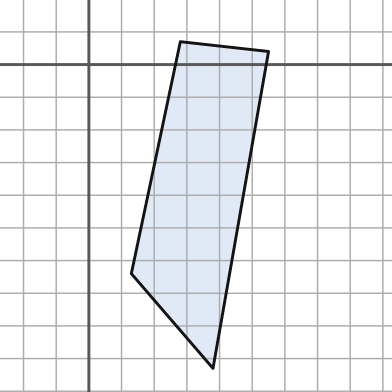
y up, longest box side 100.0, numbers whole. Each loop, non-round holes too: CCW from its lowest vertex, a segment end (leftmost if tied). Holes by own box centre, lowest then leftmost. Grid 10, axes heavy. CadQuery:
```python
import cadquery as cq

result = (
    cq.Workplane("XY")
    .moveTo(38.0, -93.0)
    .lineTo(55.0, 4.0)
    .lineTo(28.0, 7.0)
    .lineTo(13.0, -64.0)
    .close()
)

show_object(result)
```